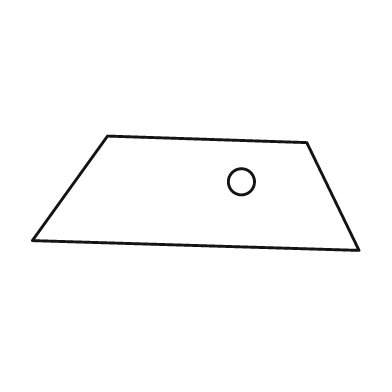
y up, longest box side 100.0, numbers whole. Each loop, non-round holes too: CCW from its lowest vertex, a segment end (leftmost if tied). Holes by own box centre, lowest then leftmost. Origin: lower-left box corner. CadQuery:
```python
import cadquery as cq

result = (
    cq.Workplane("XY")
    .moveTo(100.0, 0.0)
    .lineTo(84.0, 33.0)
    .lineTo(23.0, 35.0)
    .lineTo(0.0, 3.0)
    .close()
    .moveTo(64.0, 21.0)
    .circle(4.0)
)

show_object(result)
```